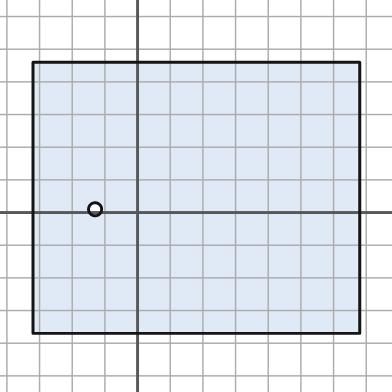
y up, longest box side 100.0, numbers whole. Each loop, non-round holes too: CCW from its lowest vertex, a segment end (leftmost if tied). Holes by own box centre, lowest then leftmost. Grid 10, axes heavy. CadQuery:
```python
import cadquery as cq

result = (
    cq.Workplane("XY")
    .moveTo(-32.0, -37.0)
    .lineTo(68.0, -37.0)
    .lineTo(68.0, 46.0)
    .lineTo(-32.0, 46.0)
    .close()
    .moveTo(-13.0, 1.0)
    .circle(2.0)
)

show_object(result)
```